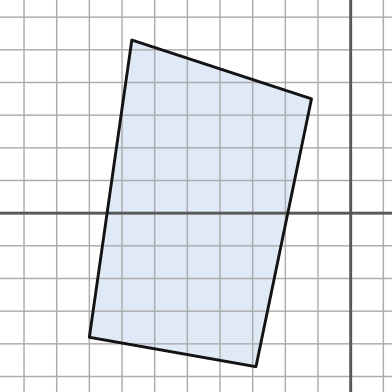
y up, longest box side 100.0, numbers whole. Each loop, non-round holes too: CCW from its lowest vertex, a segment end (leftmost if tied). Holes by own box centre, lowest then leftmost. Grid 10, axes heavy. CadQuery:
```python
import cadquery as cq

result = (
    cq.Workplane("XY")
    .moveTo(-29.0, -47.0)
    .lineTo(-12.0, 35.0)
    .lineTo(-67.0, 53.0)
    .lineTo(-80.0, -38.0)
    .close()
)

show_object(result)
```